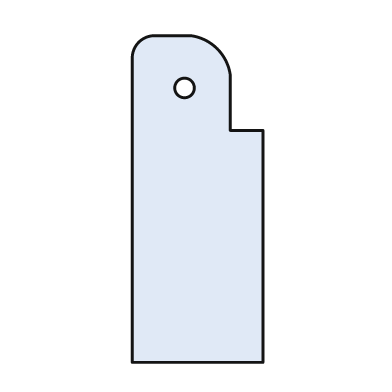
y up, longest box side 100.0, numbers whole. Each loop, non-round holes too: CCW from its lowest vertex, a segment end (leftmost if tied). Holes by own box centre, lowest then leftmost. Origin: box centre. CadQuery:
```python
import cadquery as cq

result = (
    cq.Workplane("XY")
    .moveTo(-20.0, -50.0)
    .lineTo(20.0, -50.0)
    .lineTo(20.0, 21.0)
    .lineTo(10.0, 21.0)
    .lineTo(10.0, 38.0)
    .threePointArc((6.0, 46.0), (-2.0, 50.0))
    .lineTo(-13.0, 50.0)
    .threePointArc((-18.0, 48.0), (-20.0, 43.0))
    .close()
    .moveTo(-4.0, 34.0)
    .circle(3.0)
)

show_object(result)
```